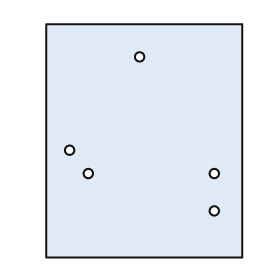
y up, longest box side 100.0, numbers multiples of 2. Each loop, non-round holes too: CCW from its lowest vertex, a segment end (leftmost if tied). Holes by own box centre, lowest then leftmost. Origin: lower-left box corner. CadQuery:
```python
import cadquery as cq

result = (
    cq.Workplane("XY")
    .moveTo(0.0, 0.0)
    .lineTo(84.0, 0.0)
    .lineTo(84.0, 100.0)
    .lineTo(0.0, 100.0)
    .close()
    .moveTo(72.0, 20.0)
    .circle(2.0)
    .moveTo(18.0, 36.0)
    .circle(2.0)
    .moveTo(72.0, 36.0)
    .circle(2.0)
    .moveTo(10.0, 46.0)
    .circle(2.0)
    .moveTo(40.0, 86.0)
    .circle(2.0)
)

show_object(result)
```